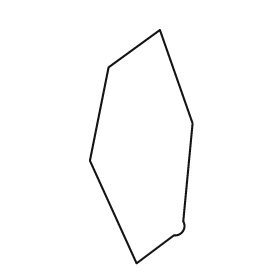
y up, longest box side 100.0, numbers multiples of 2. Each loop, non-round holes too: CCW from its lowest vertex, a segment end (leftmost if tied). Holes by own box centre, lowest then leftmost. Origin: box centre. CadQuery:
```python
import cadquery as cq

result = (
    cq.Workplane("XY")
    .moveTo(-2.0, -50.0)
    .lineTo(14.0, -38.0)
    .threePointArc((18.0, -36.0), (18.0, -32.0))
    .lineTo(22.0, 10.0)
    .lineTo(8.0, 50.0)
    .lineTo(-14.0, 34.0)
    .lineTo(-22.0, -6.0)
    .close()
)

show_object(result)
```